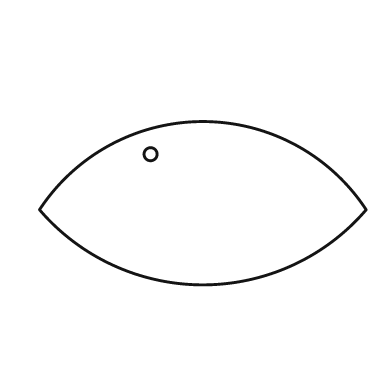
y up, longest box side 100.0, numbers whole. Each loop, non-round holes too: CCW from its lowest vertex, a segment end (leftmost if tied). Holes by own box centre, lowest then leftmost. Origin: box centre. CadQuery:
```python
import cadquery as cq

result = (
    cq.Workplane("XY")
    .moveTo(-50.0, -2.0)
    .threePointArc((0.0, -25.0), (50.0, -2.0))
    .threePointArc((0.0, 25.0), (-50.0, -2.0))
    .close()
    .moveTo(-16.0, 15.0)
    .circle(2.0)
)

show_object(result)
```